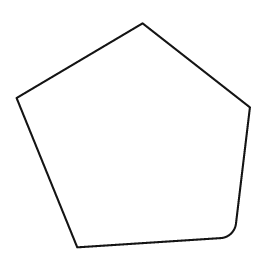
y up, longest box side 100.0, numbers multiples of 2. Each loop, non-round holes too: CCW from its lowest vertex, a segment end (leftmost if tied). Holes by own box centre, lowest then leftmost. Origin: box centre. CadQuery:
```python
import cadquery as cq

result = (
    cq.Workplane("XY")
    .moveTo(-24.0, -48.0)
    .lineTo(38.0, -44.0)
    .threePointArc((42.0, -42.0), (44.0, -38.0))
    .lineTo(50.0, 12.0)
    .lineTo(4.0, 48.0)
    .lineTo(-50.0, 16.0)
    .close()
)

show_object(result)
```